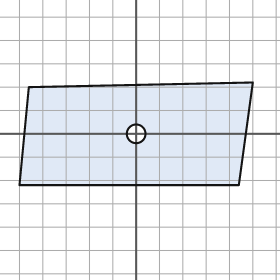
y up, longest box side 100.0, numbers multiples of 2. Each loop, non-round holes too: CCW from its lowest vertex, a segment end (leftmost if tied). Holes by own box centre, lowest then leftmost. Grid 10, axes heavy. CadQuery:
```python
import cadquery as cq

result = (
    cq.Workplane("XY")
    .moveTo(-50.0, -22.0)
    .lineTo(44.0, -22.0)
    .lineTo(50.0, 22.0)
    .lineTo(-46.0, 20.0)
    .close()
    .moveTo(0.0, 0.0)
    .circle(4.0)
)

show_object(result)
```